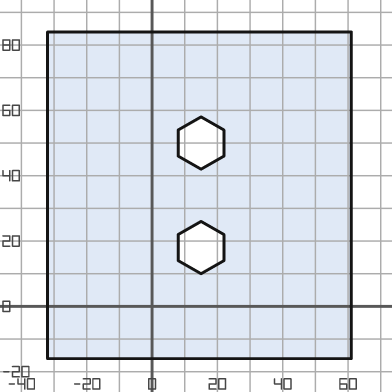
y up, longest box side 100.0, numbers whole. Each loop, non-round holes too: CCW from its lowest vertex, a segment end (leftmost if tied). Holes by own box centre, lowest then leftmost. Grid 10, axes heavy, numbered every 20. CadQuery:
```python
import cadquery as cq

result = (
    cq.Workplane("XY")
    .moveTo(-32.0, -16.0)
    .lineTo(61.0, -16.0)
    .lineTo(61.0, 84.0)
    .lineTo(-32.0, 84.0)
    .close()
    .moveTo(15.0, 10.0)
    .lineTo(22.0, 14.0)
    .lineTo(22.0, 22.0)
    .lineTo(15.0, 26.0)
    .lineTo(8.0, 22.0)
    .lineTo(8.0, 14.0)
    .close()
    .moveTo(15.0, 42.0)
    .lineTo(22.0, 46.0)
    .lineTo(22.0, 54.0)
    .lineTo(15.0, 58.0)
    .lineTo(8.0, 54.0)
    .lineTo(8.0, 46.0)
    .close()
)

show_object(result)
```